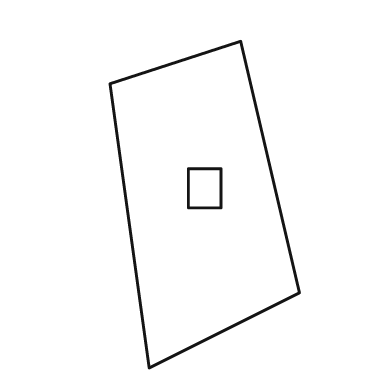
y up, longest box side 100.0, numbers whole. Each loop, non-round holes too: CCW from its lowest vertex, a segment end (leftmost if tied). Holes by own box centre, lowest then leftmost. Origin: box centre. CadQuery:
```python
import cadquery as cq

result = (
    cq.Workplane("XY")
    .moveTo(-17.0, -50.0)
    .lineTo(29.0, -27.0)
    .lineTo(11.0, 50.0)
    .lineTo(-29.0, 37.0)
    .close()
    .moveTo(-5.0, -1.0)
    .lineTo(5.0, -1.0)
    .lineTo(5.0, 11.0)
    .lineTo(-5.0, 11.0)
    .close()
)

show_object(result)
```